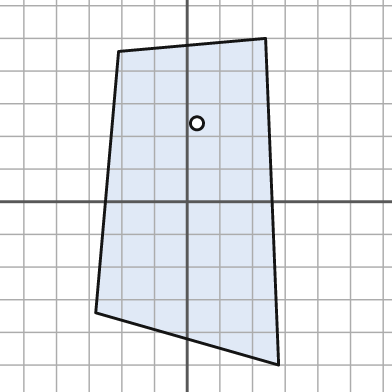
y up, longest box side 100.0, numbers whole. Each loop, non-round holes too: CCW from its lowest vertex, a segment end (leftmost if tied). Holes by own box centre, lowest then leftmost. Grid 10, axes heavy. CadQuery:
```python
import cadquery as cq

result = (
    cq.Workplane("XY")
    .moveTo(28.0, -50.0)
    .lineTo(24.0, 50.0)
    .lineTo(-21.0, 46.0)
    .lineTo(-28.0, -34.0)
    .close()
    .moveTo(3.0, 24.0)
    .circle(2.0)
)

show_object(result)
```